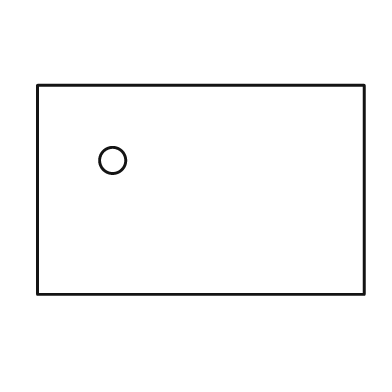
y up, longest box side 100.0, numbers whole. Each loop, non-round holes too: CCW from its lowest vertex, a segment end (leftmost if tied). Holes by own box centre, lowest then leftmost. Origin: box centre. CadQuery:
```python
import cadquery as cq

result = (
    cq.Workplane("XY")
    .moveTo(-50.0, -32.0)
    .lineTo(50.0, -32.0)
    .lineTo(50.0, 32.0)
    .lineTo(-50.0, 32.0)
    .close()
    .moveTo(-27.0, 9.0)
    .circle(4.0)
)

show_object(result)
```